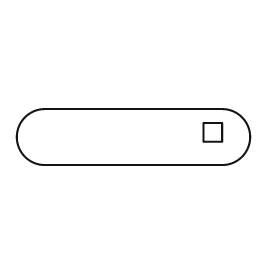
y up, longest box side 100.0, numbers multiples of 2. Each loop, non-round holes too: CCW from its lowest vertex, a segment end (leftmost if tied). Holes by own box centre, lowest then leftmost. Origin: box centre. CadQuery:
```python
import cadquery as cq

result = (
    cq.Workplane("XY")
    .moveTo(-38.0, -12.0)
    .lineTo(38.0, -12.0)
    .threePointArc((50.0, 0.0), (38.0, 12.0))
    .lineTo(-38.0, 12.0)
    .threePointArc((-50.0, 0.0), (-38.0, -12.0))
    .close()
    .moveTo(30.0, -2.0)
    .lineTo(38.0, -2.0)
    .lineTo(38.0, 6.0)
    .lineTo(30.0, 6.0)
    .close()
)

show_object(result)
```